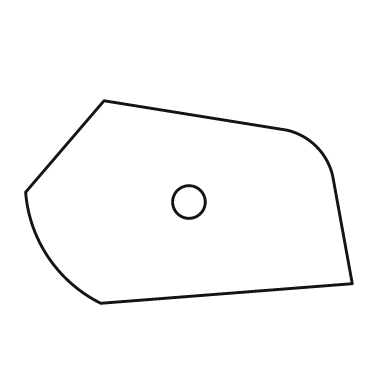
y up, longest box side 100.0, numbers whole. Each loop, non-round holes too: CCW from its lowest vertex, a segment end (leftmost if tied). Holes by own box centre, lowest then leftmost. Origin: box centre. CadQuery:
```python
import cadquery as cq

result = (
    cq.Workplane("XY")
    .moveTo(-27.0, -31.0)
    .lineTo(50.0, -25.0)
    .lineTo(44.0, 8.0)
    .threePointArc((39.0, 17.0), (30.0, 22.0))
    .lineTo(-26.0, 31.0)
    .lineTo(-50.0, 3.0)
    .threePointArc((-43.0, -17.0), (-27.0, -31.0))
    .close()
    .moveTo(0.0, 0.0)
    .circle(5.0)
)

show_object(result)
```